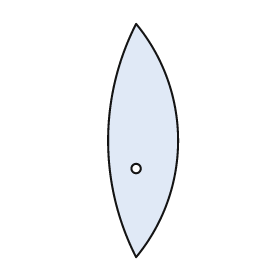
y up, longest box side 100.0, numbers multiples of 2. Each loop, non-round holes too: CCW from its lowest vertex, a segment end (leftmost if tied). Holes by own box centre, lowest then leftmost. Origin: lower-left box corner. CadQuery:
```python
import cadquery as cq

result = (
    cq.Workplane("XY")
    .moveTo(12.0, 0.0)
    .threePointArc((30.0, 50.0), (12.0, 100.0))
    .threePointArc((0.0, 50.0), (12.0, 0.0))
    .close()
    .moveTo(12.0, 38.0)
    .circle(2.0)
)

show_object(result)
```